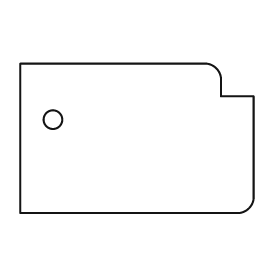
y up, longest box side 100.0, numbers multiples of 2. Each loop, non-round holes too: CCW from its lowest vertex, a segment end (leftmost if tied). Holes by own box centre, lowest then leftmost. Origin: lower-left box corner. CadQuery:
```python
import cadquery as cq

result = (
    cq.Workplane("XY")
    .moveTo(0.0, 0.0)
    .lineTo(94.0, 0.0)
    .threePointArc((98.0, 2.0), (100.0, 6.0))
    .lineTo(100.0, 50.0)
    .lineTo(86.0, 50.0)
    .lineTo(86.0, 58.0)
    .threePointArc((84.0, 62.0), (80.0, 64.0))
    .lineTo(0.0, 64.0)
    .close()
    .moveTo(14.0, 40.0)
    .circle(4.0)
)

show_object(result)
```